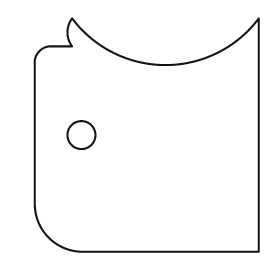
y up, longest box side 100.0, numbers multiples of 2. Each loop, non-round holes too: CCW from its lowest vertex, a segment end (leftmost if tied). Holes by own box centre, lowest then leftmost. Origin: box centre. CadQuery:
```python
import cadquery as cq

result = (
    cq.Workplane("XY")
    .moveTo(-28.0, -50.0)
    .lineTo(48.0, -50.0)
    .lineTo(48.0, 50.0)
    .threePointArc((8.0, 30.0), (-32.0, 50.0))
    .threePointArc((-34.0, 44.0), (-32.0, 38.0))
    .lineTo(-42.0, 38.0)
    .threePointArc((-46.0, 36.0), (-48.0, 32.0))
    .lineTo(-48.0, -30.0)
    .threePointArc((-42.0, -44.0), (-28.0, -50.0))
    .close()
    .moveTo(-28.0, 0.0)
    .circle(6.0)
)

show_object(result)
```